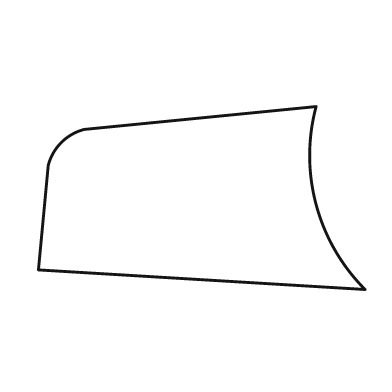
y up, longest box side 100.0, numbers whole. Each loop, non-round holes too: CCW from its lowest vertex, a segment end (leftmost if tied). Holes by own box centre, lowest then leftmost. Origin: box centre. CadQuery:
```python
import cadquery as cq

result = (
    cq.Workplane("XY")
    .moveTo(50.0, -28.0)
    .threePointArc((35.0, -2.0), (35.0, 28.0))
    .lineTo(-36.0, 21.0)
    .threePointArc((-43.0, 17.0), (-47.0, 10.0))
    .lineTo(-50.0, -22.0)
    .close()
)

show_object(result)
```